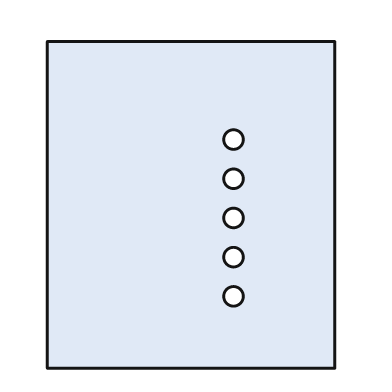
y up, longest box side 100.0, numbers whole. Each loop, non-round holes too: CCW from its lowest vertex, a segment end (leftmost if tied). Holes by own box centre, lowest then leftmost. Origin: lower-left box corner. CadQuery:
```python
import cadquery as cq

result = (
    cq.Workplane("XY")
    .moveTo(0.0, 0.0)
    .lineTo(88.0, 0.0)
    .lineTo(88.0, 100.0)
    .lineTo(0.0, 100.0)
    .close()
    .moveTo(57.0, 22.0)
    .circle(3.0)
    .moveTo(57.0, 34.0)
    .circle(3.0)
    .moveTo(57.0, 46.0)
    .circle(3.0)
    .moveTo(57.0, 58.0)
    .circle(3.0)
    .moveTo(57.0, 70.0)
    .circle(3.0)
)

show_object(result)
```